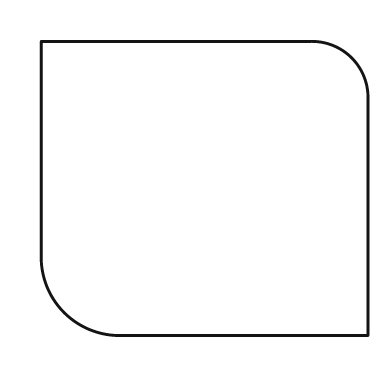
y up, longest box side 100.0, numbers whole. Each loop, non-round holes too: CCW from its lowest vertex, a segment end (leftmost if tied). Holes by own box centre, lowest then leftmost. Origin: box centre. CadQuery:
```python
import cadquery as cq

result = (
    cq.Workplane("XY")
    .moveTo(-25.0, -45.0)
    .lineTo(50.0, -45.0)
    .lineTo(50.0, 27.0)
    .threePointArc((45.0, 40.0), (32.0, 45.0))
    .lineTo(-50.0, 45.0)
    .lineTo(-50.0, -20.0)
    .threePointArc((-43.0, -38.0), (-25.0, -45.0))
    .close()
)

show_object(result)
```